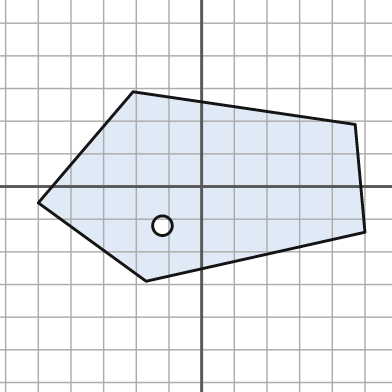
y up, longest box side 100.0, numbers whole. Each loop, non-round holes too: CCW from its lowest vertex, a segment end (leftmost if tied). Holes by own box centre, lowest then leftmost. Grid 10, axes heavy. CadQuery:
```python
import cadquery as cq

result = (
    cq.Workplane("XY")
    .moveTo(-17.0, -29.0)
    .lineTo(50.0, -14.0)
    .lineTo(47.0, 19.0)
    .lineTo(-21.0, 29.0)
    .lineTo(-50.0, -5.0)
    .close()
    .moveTo(-12.0, -12.0)
    .circle(3.0)
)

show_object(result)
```